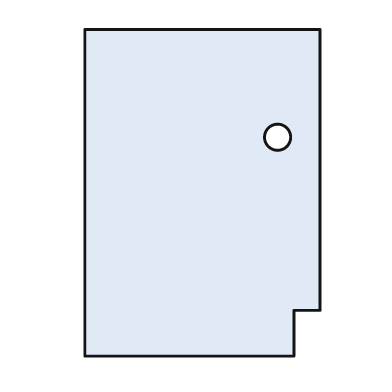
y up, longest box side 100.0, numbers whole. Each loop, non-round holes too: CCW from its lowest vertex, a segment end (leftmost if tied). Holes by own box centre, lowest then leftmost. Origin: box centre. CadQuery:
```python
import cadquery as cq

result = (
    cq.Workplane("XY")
    .moveTo(-36.0, -50.0)
    .lineTo(28.0, -50.0)
    .lineTo(28.0, -36.0)
    .lineTo(36.0, -36.0)
    .lineTo(36.0, 50.0)
    .lineTo(-36.0, 50.0)
    .close()
    .moveTo(23.0, 17.0)
    .circle(4.0)
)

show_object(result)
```